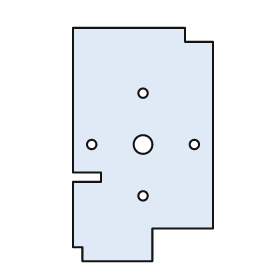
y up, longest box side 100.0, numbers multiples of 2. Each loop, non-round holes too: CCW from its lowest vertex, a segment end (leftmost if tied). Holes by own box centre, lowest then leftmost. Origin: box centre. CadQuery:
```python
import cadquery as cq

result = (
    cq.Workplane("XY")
    .moveTo(-26.0, -50.0)
    .lineTo(4.0, -50.0)
    .lineTo(4.0, -36.0)
    .lineTo(30.0, -36.0)
    .lineTo(30.0, 44.0)
    .lineTo(18.0, 44.0)
    .lineTo(18.0, 50.0)
    .lineTo(-30.0, 50.0)
    .lineTo(-30.0, -12.0)
    .lineTo(-18.0, -12.0)
    .lineTo(-18.0, -16.0)
    .lineTo(-30.0, -16.0)
    .lineTo(-30.0, -44.0)
    .lineTo(-26.0, -44.0)
    .close()
    .moveTo(0.0, -22.0)
    .circle(2.0)
    .moveTo(-22.0, 0.0)
    .circle(2.0)
    .moveTo(0.0, 0.0)
    .circle(4.0)
    .moveTo(22.0, 0.0)
    .circle(2.0)
    .moveTo(0.0, 22.0)
    .circle(2.0)
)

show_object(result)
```